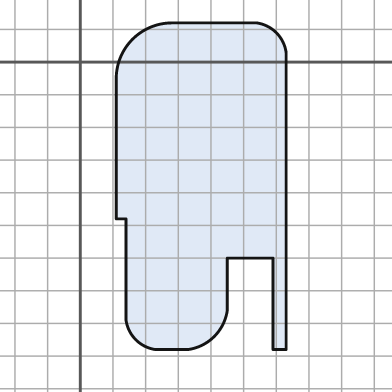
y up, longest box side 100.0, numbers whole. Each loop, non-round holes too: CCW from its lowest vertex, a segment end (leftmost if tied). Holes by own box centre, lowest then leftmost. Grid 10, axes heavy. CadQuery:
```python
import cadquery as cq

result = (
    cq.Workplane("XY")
    .moveTo(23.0, -88.0)
    .lineTo(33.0, -88.0)
    .threePointArc((41.0, -84.0), (45.0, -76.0))
    .lineTo(45.0, -60.0)
    .lineTo(59.0, -60.0)
    .lineTo(59.0, -88.0)
    .lineTo(63.0, -88.0)
    .lineTo(63.0, 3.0)
    .threePointArc((60.0, 9.0), (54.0, 12.0))
    .lineTo(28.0, 12.0)
    .threePointArc((16.0, 7.0), (11.0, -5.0))
    .lineTo(11.0, -48.0)
    .lineTo(14.0, -48.0)
    .lineTo(14.0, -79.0)
    .threePointArc((17.0, -85.0), (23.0, -88.0))
    .close()
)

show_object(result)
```